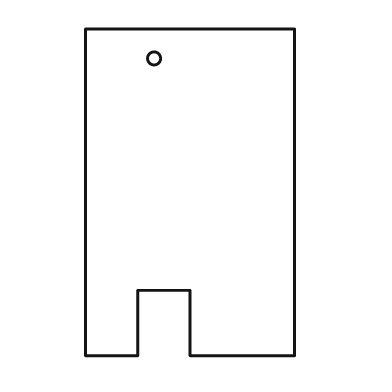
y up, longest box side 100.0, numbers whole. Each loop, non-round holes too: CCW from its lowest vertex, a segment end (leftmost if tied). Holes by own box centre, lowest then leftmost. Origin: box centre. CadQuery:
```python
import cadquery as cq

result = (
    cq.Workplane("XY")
    .moveTo(-32.0, -50.0)
    .lineTo(-16.0, -50.0)
    .lineTo(-16.0, -30.0)
    .lineTo(0.0, -30.0)
    .lineTo(0.0, -50.0)
    .lineTo(32.0, -50.0)
    .lineTo(32.0, 50.0)
    .lineTo(-32.0, 50.0)
    .close()
    .moveTo(-11.0, 41.0)
    .circle(2.0)
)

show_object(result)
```